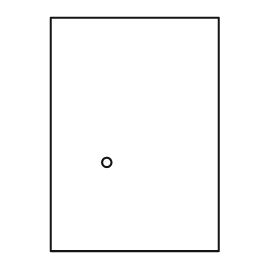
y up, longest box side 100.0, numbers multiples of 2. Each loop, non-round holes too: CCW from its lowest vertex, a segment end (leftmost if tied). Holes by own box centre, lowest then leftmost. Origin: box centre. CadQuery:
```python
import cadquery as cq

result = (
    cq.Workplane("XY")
    .moveTo(-36.0, -50.0)
    .lineTo(36.0, -50.0)
    .lineTo(36.0, 50.0)
    .lineTo(-36.0, 50.0)
    .close()
    .moveTo(-12.0, -12.0)
    .circle(2.0)
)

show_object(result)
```